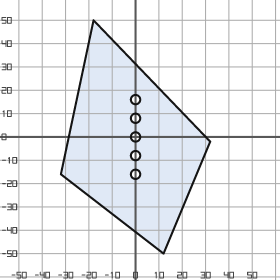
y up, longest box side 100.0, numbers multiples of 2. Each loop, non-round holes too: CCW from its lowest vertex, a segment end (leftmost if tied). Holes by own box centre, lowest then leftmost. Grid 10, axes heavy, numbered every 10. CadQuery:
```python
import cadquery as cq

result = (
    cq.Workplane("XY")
    .moveTo(12.0, -50.0)
    .lineTo(32.0, -2.0)
    .lineTo(-18.0, 50.0)
    .lineTo(-32.0, -16.0)
    .close()
    .moveTo(0.0, -16.0)
    .circle(2.0)
    .moveTo(0.0, -8.0)
    .circle(2.0)
    .moveTo(0.0, 0.0)
    .circle(2.0)
    .moveTo(0.0, 8.0)
    .circle(2.0)
    .moveTo(0.0, 16.0)
    .circle(2.0)
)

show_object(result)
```